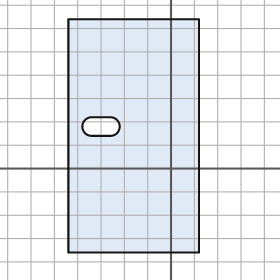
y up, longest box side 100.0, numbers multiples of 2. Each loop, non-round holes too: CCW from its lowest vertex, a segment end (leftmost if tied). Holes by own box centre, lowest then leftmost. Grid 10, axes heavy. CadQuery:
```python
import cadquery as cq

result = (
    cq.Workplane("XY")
    .moveTo(-44.0, -36.0)
    .lineTo(12.0, -36.0)
    .lineTo(12.0, 64.0)
    .lineTo(-44.0, 64.0)
    .close()
    .moveTo(-34.0, 14.0)
    .lineTo(-26.0, 14.0)
    .threePointArc((-22.0, 18.0), (-26.0, 22.0))
    .lineTo(-34.0, 22.0)
    .threePointArc((-38.0, 18.0), (-34.0, 14.0))
    .close()
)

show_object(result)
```